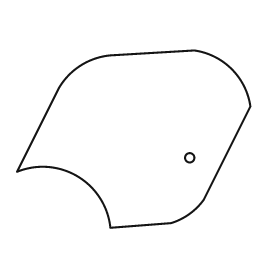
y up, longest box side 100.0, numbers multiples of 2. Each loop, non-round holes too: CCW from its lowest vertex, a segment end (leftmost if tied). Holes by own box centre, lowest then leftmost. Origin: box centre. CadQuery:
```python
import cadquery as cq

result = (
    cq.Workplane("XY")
    .moveTo(-10.0, -38.0)
    .lineTo(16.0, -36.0)
    .threePointArc((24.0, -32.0), (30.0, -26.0))
    .lineTo(50.0, 14.0)
    .threePointArc((42.0, 30.0), (26.0, 38.0))
    .lineTo(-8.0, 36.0)
    .threePointArc((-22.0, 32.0), (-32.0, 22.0))
    .lineTo(-50.0, -14.0)
    .threePointArc((-24.0, -16.0), (-10.0, -38.0))
    .close()
    .moveTo(24.0, -8.0)
    .circle(2.0)
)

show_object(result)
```